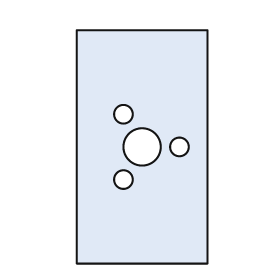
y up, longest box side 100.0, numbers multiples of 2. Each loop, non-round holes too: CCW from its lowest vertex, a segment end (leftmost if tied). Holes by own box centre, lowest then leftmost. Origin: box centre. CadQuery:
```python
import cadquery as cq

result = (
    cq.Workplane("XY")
    .moveTo(-28.0, -50.0)
    .lineTo(28.0, -50.0)
    .lineTo(28.0, 50.0)
    .lineTo(-28.0, 50.0)
    .close()
    .moveTo(-8.0, -14.0)
    .circle(4.0)
    .moveTo(0.0, 0.0)
    .circle(8.0)
    .moveTo(16.0, 0.0)
    .circle(4.0)
    .moveTo(-8.0, 14.0)
    .circle(4.0)
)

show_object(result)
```